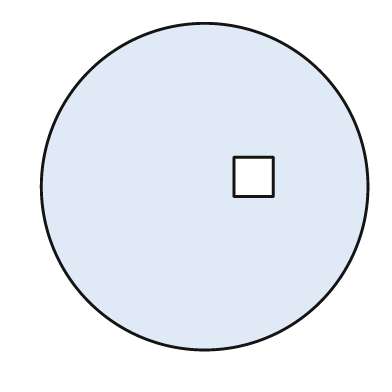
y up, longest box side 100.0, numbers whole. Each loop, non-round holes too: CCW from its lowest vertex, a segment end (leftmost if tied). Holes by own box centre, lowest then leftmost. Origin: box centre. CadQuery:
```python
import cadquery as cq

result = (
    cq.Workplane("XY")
    .moveTo(0.0, 0.0)
    .circle(50.0)
    .moveTo(9.0, -3.0)
    .lineTo(21.0, -3.0)
    .lineTo(21.0, 9.0)
    .lineTo(9.0, 9.0)
    .close()
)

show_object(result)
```